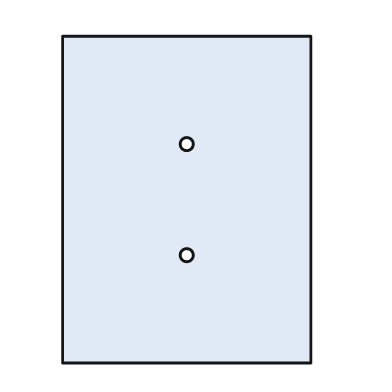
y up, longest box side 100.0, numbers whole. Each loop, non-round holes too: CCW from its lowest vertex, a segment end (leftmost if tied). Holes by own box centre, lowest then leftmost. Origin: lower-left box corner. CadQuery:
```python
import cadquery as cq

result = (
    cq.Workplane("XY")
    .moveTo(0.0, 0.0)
    .lineTo(76.0, 0.0)
    .lineTo(76.0, 100.0)
    .lineTo(0.0, 100.0)
    .close()
    .moveTo(38.0, 33.0)
    .circle(2.0)
    .moveTo(38.0, 67.0)
    .circle(2.0)
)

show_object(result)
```